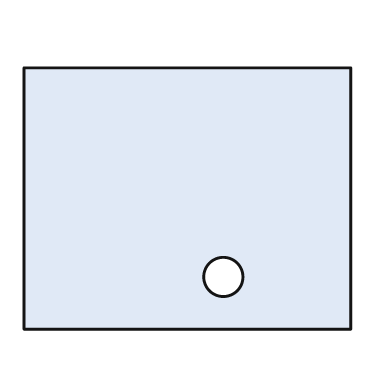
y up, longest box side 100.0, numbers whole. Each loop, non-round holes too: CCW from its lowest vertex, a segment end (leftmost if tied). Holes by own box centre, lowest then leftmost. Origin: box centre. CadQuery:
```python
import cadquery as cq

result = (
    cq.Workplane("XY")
    .moveTo(-50.0, -40.0)
    .lineTo(50.0, -40.0)
    .lineTo(50.0, 40.0)
    .lineTo(-50.0, 40.0)
    .close()
    .moveTo(11.0, -24.0)
    .circle(6.0)
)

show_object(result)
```